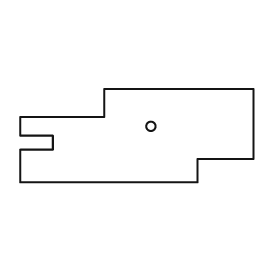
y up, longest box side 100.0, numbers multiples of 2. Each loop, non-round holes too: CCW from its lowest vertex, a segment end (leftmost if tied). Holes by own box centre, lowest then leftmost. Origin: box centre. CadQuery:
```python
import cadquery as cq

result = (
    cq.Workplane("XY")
    .moveTo(-50.0, -20.0)
    .lineTo(26.0, -20.0)
    .lineTo(26.0, -10.0)
    .lineTo(50.0, -10.0)
    .lineTo(50.0, 20.0)
    .lineTo(-14.0, 20.0)
    .lineTo(-14.0, 8.0)
    .lineTo(-50.0, 8.0)
    .lineTo(-50.0, 0.0)
    .lineTo(-36.0, 0.0)
    .lineTo(-36.0, -6.0)
    .lineTo(-50.0, -6.0)
    .close()
    .moveTo(6.0, 4.0)
    .circle(2.0)
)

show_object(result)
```